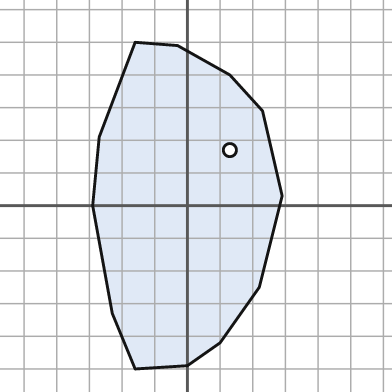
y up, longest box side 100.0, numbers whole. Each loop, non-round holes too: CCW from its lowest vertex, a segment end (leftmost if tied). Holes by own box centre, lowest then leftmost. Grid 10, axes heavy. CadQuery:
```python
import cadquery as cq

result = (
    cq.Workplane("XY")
    .moveTo(-16.0, -50.0)
    .lineTo(0.0, -49.0)
    .lineTo(10.0, -42.0)
    .lineTo(22.0, -25.0)
    .lineTo(29.0, 3.0)
    .lineTo(23.0, 29.0)
    .lineTo(13.0, 40.0)
    .lineTo(-3.0, 49.0)
    .lineTo(-16.0, 50.0)
    .lineTo(-27.0, 21.0)
    .lineTo(-29.0, 0.0)
    .lineTo(-23.0, -33.0)
    .close()
    .moveTo(13.0, 17.0)
    .circle(2.0)
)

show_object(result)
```